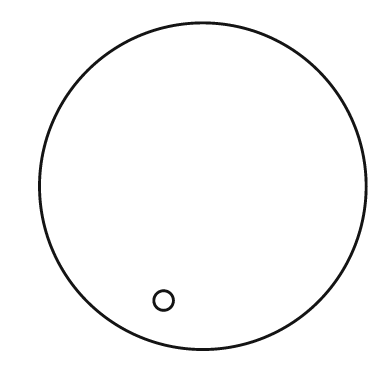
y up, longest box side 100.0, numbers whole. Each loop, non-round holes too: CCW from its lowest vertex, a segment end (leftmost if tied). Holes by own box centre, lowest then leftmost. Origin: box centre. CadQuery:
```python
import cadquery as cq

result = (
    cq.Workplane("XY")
    .moveTo(0.0, 0.0)
    .circle(50.0)
    .moveTo(-12.0, -35.0)
    .circle(3.0)
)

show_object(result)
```